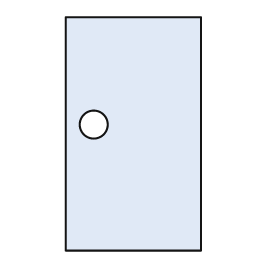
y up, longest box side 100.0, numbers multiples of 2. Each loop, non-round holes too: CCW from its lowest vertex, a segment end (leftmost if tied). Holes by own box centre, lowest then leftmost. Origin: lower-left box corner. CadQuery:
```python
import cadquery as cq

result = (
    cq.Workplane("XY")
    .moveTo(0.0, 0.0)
    .lineTo(58.0, 0.0)
    .lineTo(58.0, 100.0)
    .lineTo(0.0, 100.0)
    .close()
    .moveTo(12.0, 54.0)
    .circle(6.0)
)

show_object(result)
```